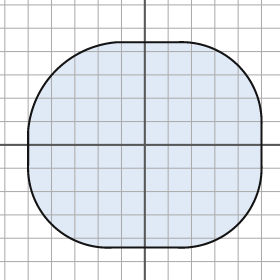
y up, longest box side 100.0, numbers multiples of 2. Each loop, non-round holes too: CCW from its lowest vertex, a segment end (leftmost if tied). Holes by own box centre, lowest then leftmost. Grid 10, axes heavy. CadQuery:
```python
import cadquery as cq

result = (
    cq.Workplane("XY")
    .moveTo(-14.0, -44.0)
    .lineTo(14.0, -44.0)
    .threePointArc((40.0, -34.0), (50.0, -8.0))
    .lineTo(50.0, 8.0)
    .threePointArc((40.0, 34.0), (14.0, 44.0))
    .lineTo(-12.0, 44.0)
    .threePointArc((-38.0, 32.0), (-50.0, 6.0))
    .lineTo(-50.0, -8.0)
    .threePointArc((-40.0, -34.0), (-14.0, -44.0))
    .close()
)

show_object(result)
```